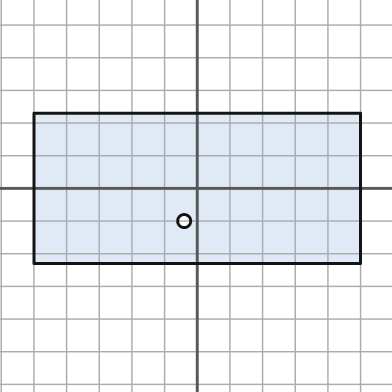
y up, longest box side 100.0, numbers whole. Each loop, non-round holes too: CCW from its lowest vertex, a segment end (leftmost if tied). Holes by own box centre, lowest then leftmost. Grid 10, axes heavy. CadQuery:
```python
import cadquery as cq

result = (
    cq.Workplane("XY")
    .moveTo(-50.0, -23.0)
    .lineTo(50.0, -23.0)
    .lineTo(50.0, 23.0)
    .lineTo(-50.0, 23.0)
    .close()
    .moveTo(-4.0, -10.0)
    .circle(2.0)
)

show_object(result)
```